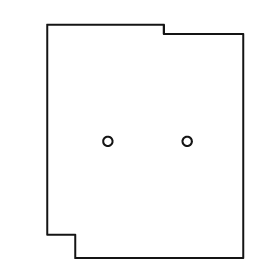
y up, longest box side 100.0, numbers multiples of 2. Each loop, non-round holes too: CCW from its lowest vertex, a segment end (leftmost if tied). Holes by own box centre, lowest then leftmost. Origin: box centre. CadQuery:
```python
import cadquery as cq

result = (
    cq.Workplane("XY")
    .moveTo(-30.0, -50.0)
    .lineTo(42.0, -50.0)
    .lineTo(42.0, 46.0)
    .lineTo(8.0, 46.0)
    .lineTo(8.0, 50.0)
    .lineTo(-42.0, 50.0)
    .lineTo(-42.0, -40.0)
    .lineTo(-30.0, -40.0)
    .close()
    .moveTo(-16.0, 0.0)
    .circle(2.0)
    .moveTo(18.0, 0.0)
    .circle(2.0)
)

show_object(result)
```